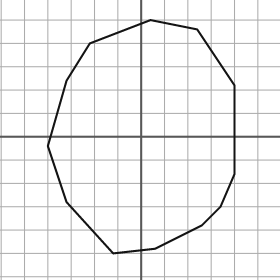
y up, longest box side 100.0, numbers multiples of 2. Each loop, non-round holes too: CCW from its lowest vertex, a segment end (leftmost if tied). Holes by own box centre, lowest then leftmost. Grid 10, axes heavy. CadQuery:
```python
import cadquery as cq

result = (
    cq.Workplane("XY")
    .moveTo(-12.0, -50.0)
    .lineTo(6.0, -48.0)
    .lineTo(26.0, -38.0)
    .lineTo(34.0, -30.0)
    .lineTo(40.0, -16.0)
    .lineTo(40.0, 22.0)
    .lineTo(24.0, 46.0)
    .lineTo(4.0, 50.0)
    .lineTo(-22.0, 40.0)
    .lineTo(-32.0, 24.0)
    .lineTo(-40.0, -4.0)
    .lineTo(-32.0, -28.0)
    .close()
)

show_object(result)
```